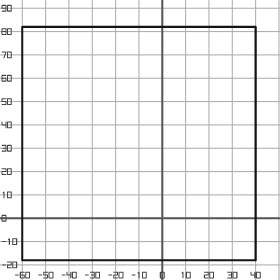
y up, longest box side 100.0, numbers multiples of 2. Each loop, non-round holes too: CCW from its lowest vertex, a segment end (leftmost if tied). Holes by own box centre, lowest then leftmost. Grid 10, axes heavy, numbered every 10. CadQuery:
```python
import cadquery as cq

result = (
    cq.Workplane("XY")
    .moveTo(-60.0, -18.0)
    .lineTo(40.0, -18.0)
    .lineTo(40.0, 82.0)
    .lineTo(-60.0, 82.0)
    .close()
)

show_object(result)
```